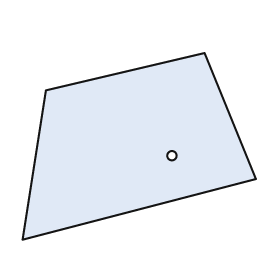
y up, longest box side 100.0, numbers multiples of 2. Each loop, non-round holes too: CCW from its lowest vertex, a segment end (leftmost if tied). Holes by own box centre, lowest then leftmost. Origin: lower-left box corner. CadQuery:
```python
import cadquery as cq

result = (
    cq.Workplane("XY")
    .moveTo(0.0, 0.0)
    .lineTo(100.0, 26.0)
    .lineTo(78.0, 80.0)
    .lineTo(10.0, 64.0)
    .close()
    .moveTo(64.0, 36.0)
    .circle(2.0)
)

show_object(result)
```